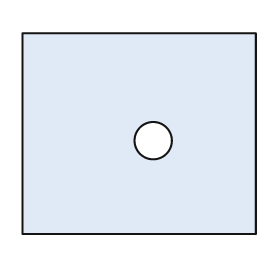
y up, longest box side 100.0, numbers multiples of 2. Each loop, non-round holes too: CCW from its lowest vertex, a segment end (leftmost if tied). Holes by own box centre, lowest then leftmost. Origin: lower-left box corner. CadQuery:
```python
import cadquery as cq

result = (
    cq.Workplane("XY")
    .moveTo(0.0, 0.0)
    .lineTo(100.0, 0.0)
    .lineTo(100.0, 86.0)
    .lineTo(0.0, 86.0)
    .close()
    .moveTo(56.0, 40.0)
    .circle(8.0)
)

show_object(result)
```